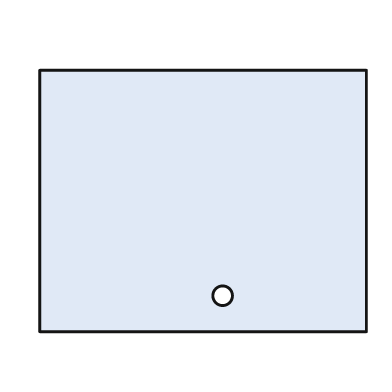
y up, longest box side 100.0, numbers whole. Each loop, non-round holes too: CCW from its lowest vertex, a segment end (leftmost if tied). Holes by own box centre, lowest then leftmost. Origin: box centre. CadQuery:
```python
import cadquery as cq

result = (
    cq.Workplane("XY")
    .moveTo(-50.0, -40.0)
    .lineTo(50.0, -40.0)
    .lineTo(50.0, 40.0)
    .lineTo(-50.0, 40.0)
    .close()
    .moveTo(6.0, -29.0)
    .circle(3.0)
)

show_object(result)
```